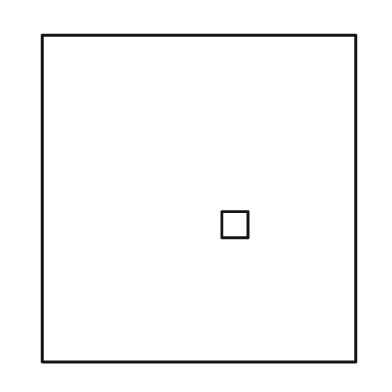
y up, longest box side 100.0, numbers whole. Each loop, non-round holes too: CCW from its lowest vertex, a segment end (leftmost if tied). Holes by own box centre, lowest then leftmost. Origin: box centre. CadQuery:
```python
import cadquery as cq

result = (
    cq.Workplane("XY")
    .moveTo(-48.0, -50.0)
    .lineTo(48.0, -50.0)
    .lineTo(48.0, 50.0)
    .lineTo(-48.0, 50.0)
    .close()
    .moveTo(7.0, -12.0)
    .lineTo(15.0, -12.0)
    .lineTo(15.0, -4.0)
    .lineTo(7.0, -4.0)
    .close()
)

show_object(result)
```